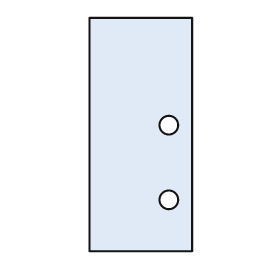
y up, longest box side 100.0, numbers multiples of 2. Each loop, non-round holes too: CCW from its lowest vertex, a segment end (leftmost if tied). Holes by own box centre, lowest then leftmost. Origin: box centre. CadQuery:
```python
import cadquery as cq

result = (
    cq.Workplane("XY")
    .moveTo(-22.0, -50.0)
    .lineTo(22.0, -50.0)
    .lineTo(22.0, 50.0)
    .lineTo(-22.0, 50.0)
    .close()
    .moveTo(12.0, -28.0)
    .circle(4.0)
    .moveTo(12.0, 4.0)
    .circle(4.0)
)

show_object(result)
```